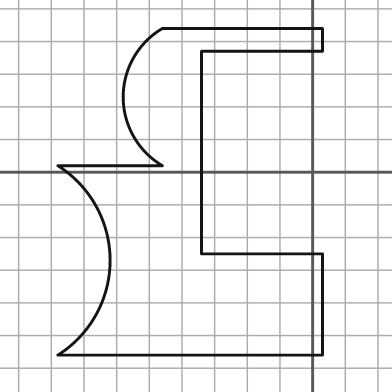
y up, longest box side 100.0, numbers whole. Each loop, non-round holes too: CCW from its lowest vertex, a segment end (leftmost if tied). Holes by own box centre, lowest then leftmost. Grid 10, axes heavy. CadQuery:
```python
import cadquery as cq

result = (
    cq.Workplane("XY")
    .moveTo(-78.0, -56.0)
    .lineTo(3.0, -56.0)
    .lineTo(3.0, -25.0)
    .lineTo(-34.0, -25.0)
    .lineTo(-34.0, 37.0)
    .lineTo(3.0, 37.0)
    .lineTo(3.0, 44.0)
    .lineTo(-46.0, 44.0)
    .threePointArc((-58.0, 23.0), (-46.0, 2.0))
    .lineTo(-78.0, 2.0)
    .threePointArc((-62.0, -27.0), (-78.0, -56.0))
    .close()
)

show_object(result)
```